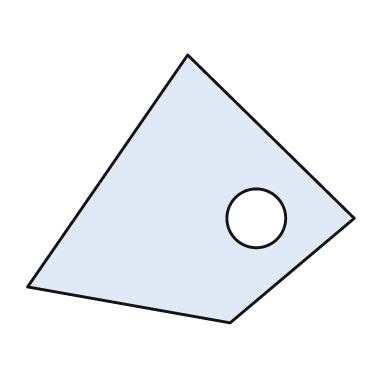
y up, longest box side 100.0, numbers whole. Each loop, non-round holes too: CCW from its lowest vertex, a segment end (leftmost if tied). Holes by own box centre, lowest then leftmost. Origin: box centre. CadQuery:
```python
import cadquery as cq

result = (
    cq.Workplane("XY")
    .moveTo(12.0, -41.0)
    .lineTo(50.0, -9.0)
    .lineTo(-1.0, 41.0)
    .lineTo(-50.0, -30.0)
    .close()
    .moveTo(20.0, -9.0)
    .circle(9.0)
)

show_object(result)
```